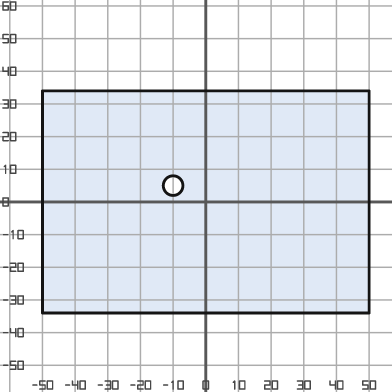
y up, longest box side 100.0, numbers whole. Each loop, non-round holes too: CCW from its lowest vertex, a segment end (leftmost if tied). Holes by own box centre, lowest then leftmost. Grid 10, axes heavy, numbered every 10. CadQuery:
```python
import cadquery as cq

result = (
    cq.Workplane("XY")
    .moveTo(-50.0, -34.0)
    .lineTo(50.0, -34.0)
    .lineTo(50.0, 34.0)
    .lineTo(-50.0, 34.0)
    .close()
    .moveTo(-10.0, 5.0)
    .circle(3.0)
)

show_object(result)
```